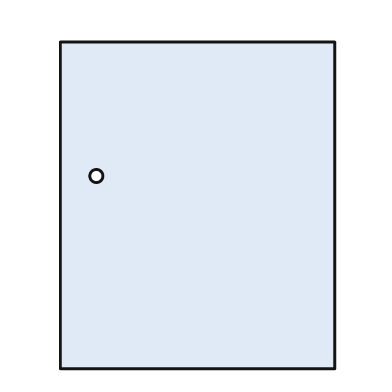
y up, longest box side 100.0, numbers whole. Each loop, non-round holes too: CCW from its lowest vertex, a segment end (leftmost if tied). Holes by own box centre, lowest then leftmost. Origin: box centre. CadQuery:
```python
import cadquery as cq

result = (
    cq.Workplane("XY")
    .moveTo(-42.0, -50.0)
    .lineTo(42.0, -50.0)
    .lineTo(42.0, 50.0)
    .lineTo(-42.0, 50.0)
    .close()
    .moveTo(-31.0, 9.0)
    .circle(2.0)
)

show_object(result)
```